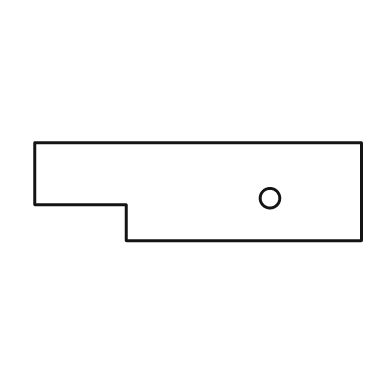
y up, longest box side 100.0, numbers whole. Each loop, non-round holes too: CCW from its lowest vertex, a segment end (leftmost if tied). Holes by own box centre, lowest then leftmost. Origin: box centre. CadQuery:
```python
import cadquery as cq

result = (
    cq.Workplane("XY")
    .moveTo(-22.0, -15.0)
    .lineTo(50.0, -15.0)
    .lineTo(50.0, 15.0)
    .lineTo(-50.0, 15.0)
    .lineTo(-50.0, -4.0)
    .lineTo(-22.0, -4.0)
    .close()
    .moveTo(22.0, -2.0)
    .circle(3.0)
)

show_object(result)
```